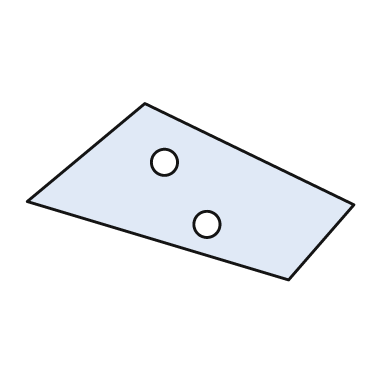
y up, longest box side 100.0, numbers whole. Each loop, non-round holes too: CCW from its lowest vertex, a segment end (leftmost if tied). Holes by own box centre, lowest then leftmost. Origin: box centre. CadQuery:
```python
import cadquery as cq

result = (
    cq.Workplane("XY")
    .moveTo(30.0, -27.0)
    .lineTo(50.0, -4.0)
    .lineTo(-14.0, 27.0)
    .lineTo(-50.0, -3.0)
    .close()
    .moveTo(5.0, -10.0)
    .circle(4.0)
    .moveTo(-8.0, 9.0)
    .circle(4.0)
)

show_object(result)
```